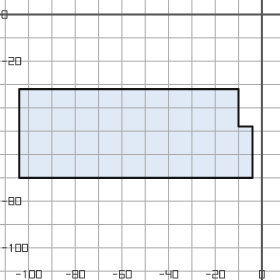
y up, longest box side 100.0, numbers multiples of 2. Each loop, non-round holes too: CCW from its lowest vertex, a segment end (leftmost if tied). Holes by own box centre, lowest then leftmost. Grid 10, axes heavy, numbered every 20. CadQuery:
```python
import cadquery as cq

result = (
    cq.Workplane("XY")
    .moveTo(-104.0, -70.0)
    .lineTo(-4.0, -70.0)
    .lineTo(-4.0, -48.0)
    .lineTo(-10.0, -48.0)
    .lineTo(-10.0, -32.0)
    .lineTo(-104.0, -32.0)
    .close()
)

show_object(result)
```